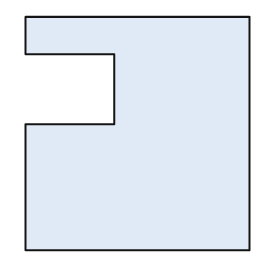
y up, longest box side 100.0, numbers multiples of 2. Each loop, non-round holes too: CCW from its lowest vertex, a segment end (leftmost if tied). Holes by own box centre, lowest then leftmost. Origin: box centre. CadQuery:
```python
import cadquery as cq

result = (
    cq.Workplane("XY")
    .moveTo(-48.0, -50.0)
    .lineTo(48.0, -50.0)
    .lineTo(48.0, 50.0)
    .lineTo(-48.0, 50.0)
    .lineTo(-48.0, 34.0)
    .lineTo(-10.0, 34.0)
    .lineTo(-10.0, 4.0)
    .lineTo(-48.0, 4.0)
    .close()
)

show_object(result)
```